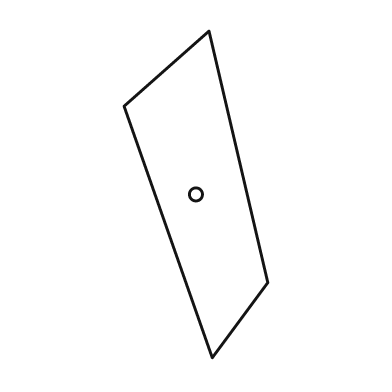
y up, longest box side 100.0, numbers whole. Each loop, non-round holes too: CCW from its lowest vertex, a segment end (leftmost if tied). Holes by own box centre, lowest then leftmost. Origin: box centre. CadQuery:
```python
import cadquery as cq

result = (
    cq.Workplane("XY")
    .moveTo(5.0, -50.0)
    .lineTo(22.0, -27.0)
    .lineTo(4.0, 50.0)
    .lineTo(-22.0, 27.0)
    .close()
    .moveTo(0.0, 0.0)
    .circle(2.0)
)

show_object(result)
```